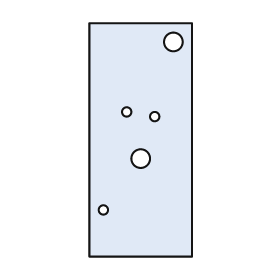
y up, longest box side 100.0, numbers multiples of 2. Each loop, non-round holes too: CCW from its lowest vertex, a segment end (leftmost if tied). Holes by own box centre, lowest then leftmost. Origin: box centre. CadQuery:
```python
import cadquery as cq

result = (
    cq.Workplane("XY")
    .moveTo(-22.0, -50.0)
    .lineTo(22.0, -50.0)
    .lineTo(22.0, 50.0)
    .lineTo(-22.0, 50.0)
    .close()
    .moveTo(-16.0, -30.0)
    .circle(2.0)
    .moveTo(0.0, -8.0)
    .circle(4.0)
    .moveTo(6.0, 10.0)
    .circle(2.0)
    .moveTo(-6.0, 12.0)
    .circle(2.0)
    .moveTo(14.0, 42.0)
    .circle(4.0)
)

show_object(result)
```